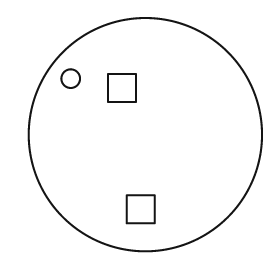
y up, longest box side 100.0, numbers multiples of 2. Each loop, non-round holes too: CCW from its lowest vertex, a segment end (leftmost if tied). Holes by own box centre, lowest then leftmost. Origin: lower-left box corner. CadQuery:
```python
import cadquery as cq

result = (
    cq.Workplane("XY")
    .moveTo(50.0, 50.0)
    .circle(50.0)
    .moveTo(42.0, 12.0)
    .lineTo(54.0, 12.0)
    .lineTo(54.0, 24.0)
    .lineTo(42.0, 24.0)
    .close()
    .moveTo(34.0, 64.0)
    .lineTo(46.0, 64.0)
    .lineTo(46.0, 76.0)
    .lineTo(34.0, 76.0)
    .close()
    .moveTo(18.0, 74.0)
    .circle(4.0)
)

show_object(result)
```